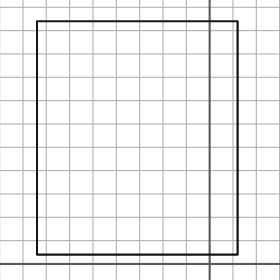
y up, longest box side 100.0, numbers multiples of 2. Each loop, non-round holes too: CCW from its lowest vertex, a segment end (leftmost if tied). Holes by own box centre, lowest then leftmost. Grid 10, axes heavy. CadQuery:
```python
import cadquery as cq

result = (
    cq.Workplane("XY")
    .moveTo(-74.0, 4.0)
    .lineTo(12.0, 4.0)
    .lineTo(12.0, 104.0)
    .lineTo(-74.0, 104.0)
    .close()
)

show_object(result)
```